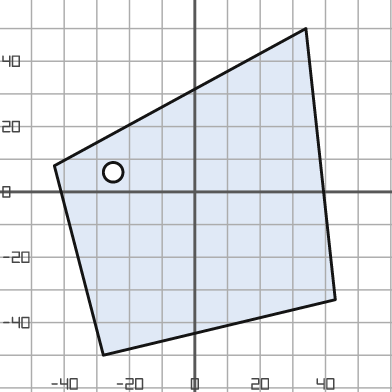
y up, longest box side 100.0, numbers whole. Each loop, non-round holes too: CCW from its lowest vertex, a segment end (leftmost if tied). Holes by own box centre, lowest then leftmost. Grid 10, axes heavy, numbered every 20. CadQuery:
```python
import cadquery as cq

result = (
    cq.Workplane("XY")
    .moveTo(-28.0, -50.0)
    .lineTo(43.0, -33.0)
    .lineTo(34.0, 50.0)
    .lineTo(-43.0, 8.0)
    .close()
    .moveTo(-25.0, 6.0)
    .circle(3.0)
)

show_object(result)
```